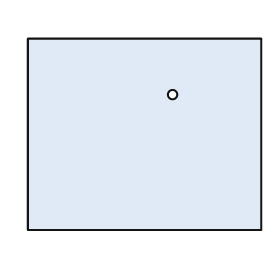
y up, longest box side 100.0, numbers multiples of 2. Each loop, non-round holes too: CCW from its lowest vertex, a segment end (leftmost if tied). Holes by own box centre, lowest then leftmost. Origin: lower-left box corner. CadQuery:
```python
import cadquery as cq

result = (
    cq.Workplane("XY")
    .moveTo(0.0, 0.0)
    .lineTo(100.0, 0.0)
    .lineTo(100.0, 82.0)
    .lineTo(0.0, 82.0)
    .close()
    .moveTo(62.0, 58.0)
    .circle(2.0)
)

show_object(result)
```